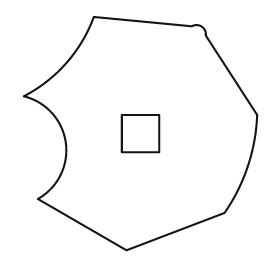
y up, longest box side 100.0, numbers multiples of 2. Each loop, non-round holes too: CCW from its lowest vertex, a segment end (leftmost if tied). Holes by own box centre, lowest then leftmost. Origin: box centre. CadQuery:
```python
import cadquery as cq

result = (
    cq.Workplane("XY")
    .moveTo(-6.0, -50.0)
    .lineTo(36.0, -34.0)
    .threePointArc((46.0, -14.0), (50.0, 8.0))
    .lineTo(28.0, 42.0)
    .threePointArc((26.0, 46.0), (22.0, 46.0))
    .lineTo(-20.0, 50.0)
    .threePointArc((-32.0, 30.0), (-50.0, 16.0))
    .threePointArc((-32.0, -4.0), (-44.0, -28.0))
    .close()
    .moveTo(-8.0, -8.0)
    .lineTo(8.0, -8.0)
    .lineTo(8.0, 8.0)
    .lineTo(-8.0, 8.0)
    .close()
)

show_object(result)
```